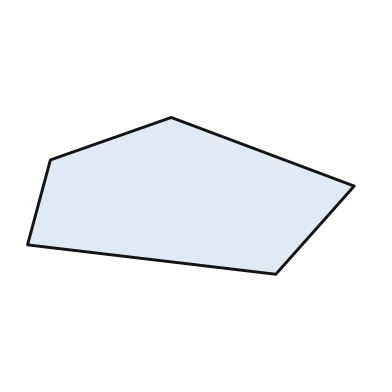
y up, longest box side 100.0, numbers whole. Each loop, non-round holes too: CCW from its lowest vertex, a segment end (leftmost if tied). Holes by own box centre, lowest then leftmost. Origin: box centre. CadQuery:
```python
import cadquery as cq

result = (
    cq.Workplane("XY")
    .moveTo(26.0, -24.0)
    .lineTo(50.0, 3.0)
    .lineTo(-6.0, 24.0)
    .lineTo(-43.0, 11.0)
    .lineTo(-50.0, -15.0)
    .close()
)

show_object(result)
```